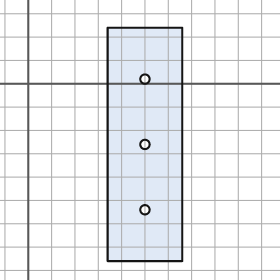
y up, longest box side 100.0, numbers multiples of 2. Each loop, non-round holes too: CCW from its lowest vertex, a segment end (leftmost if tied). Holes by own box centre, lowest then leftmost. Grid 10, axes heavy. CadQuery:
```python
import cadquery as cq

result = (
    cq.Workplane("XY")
    .moveTo(34.0, -76.0)
    .lineTo(66.0, -76.0)
    .lineTo(66.0, 24.0)
    .lineTo(34.0, 24.0)
    .close()
    .moveTo(50.0, -54.0)
    .circle(2.0)
    .moveTo(50.0, -26.0)
    .circle(2.0)
    .moveTo(50.0, 2.0)
    .circle(2.0)
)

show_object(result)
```